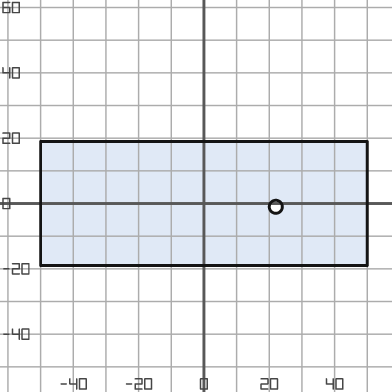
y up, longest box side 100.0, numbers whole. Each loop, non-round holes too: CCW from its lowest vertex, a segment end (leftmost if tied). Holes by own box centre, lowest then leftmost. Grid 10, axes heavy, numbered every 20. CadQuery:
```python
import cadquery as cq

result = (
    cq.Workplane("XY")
    .moveTo(-50.0, -19.0)
    .lineTo(50.0, -19.0)
    .lineTo(50.0, 19.0)
    .lineTo(-50.0, 19.0)
    .close()
    .moveTo(22.0, -1.0)
    .circle(2.0)
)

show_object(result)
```